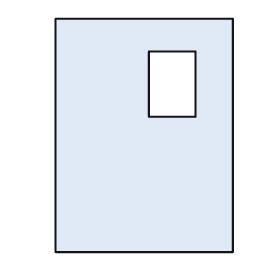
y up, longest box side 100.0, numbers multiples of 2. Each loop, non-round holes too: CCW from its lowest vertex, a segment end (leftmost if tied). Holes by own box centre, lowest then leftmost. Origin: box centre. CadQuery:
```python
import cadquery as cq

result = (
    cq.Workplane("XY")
    .moveTo(-38.0, -50.0)
    .lineTo(38.0, -50.0)
    .lineTo(38.0, 50.0)
    .lineTo(-38.0, 50.0)
    .close()
    .moveTo(2.0, 8.0)
    .lineTo(22.0, 8.0)
    .lineTo(22.0, 36.0)
    .lineTo(2.0, 36.0)
    .close()
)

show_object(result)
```